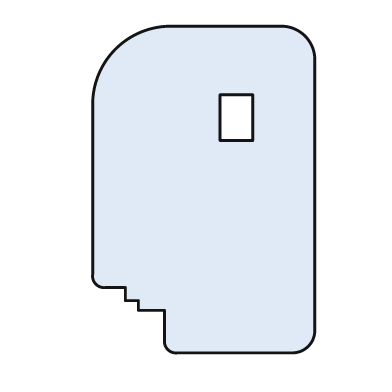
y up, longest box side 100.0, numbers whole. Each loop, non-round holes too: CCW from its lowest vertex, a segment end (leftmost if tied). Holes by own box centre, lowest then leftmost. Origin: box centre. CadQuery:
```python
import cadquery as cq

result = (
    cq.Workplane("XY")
    .moveTo(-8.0, -50.0)
    .lineTo(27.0, -50.0)
    .threePointArc((32.0, -48.0), (34.0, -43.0))
    .lineTo(34.0, 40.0)
    .threePointArc((31.0, 47.0), (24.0, 50.0))
    .lineTo(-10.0, 50.0)
    .threePointArc((-27.0, 43.0), (-34.0, 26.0))
    .lineTo(-34.0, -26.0)
    .threePointArc((-33.0, -29.0), (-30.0, -30.0))
    .lineTo(-24.0, -30.0)
    .lineTo(-24.0, -34.0)
    .lineTo(-20.0, -34.0)
    .lineTo(-20.0, -37.0)
    .lineTo(-12.0, -37.0)
    .lineTo(-12.0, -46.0)
    .threePointArc((-11.0, -49.0), (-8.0, -50.0))
    .close()
    .moveTo(5.0, 15.0)
    .lineTo(15.0, 15.0)
    .lineTo(15.0, 29.0)
    .lineTo(5.0, 29.0)
    .close()
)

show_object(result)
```